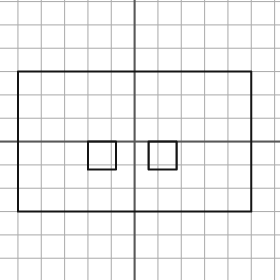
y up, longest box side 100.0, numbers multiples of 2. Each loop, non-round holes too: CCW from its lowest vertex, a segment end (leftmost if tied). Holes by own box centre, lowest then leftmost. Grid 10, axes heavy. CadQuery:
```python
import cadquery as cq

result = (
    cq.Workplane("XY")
    .moveTo(-50.0, -30.0)
    .lineTo(50.0, -30.0)
    .lineTo(50.0, 30.0)
    .lineTo(-50.0, 30.0)
    .close()
    .moveTo(-20.0, -12.0)
    .lineTo(-8.0, -12.0)
    .lineTo(-8.0, 0.0)
    .lineTo(-20.0, 0.0)
    .close()
    .moveTo(6.0, -12.0)
    .lineTo(18.0, -12.0)
    .lineTo(18.0, 0.0)
    .lineTo(6.0, 0.0)
    .close()
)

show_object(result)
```